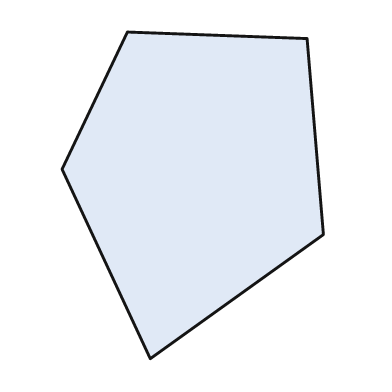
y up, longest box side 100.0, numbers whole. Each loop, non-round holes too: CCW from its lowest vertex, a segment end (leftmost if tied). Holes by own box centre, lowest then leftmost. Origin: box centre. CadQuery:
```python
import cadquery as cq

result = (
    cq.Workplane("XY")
    .moveTo(-13.0, -50.0)
    .lineTo(40.0, -12.0)
    .lineTo(35.0, 48.0)
    .lineTo(-20.0, 50.0)
    .lineTo(-40.0, 8.0)
    .close()
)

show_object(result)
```